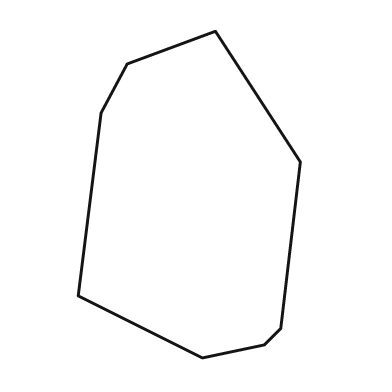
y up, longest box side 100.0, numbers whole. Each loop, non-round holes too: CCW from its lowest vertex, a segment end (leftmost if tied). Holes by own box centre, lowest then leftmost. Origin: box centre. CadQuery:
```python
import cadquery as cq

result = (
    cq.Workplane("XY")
    .moveTo(4.0, -50.0)
    .lineTo(23.0, -46.0)
    .lineTo(28.0, -41.0)
    .lineTo(34.0, 10.0)
    .lineTo(8.0, 50.0)
    .lineTo(-19.0, 40.0)
    .lineTo(-27.0, 25.0)
    .lineTo(-34.0, -31.0)
    .close()
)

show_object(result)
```